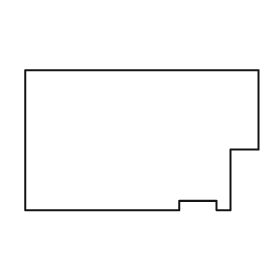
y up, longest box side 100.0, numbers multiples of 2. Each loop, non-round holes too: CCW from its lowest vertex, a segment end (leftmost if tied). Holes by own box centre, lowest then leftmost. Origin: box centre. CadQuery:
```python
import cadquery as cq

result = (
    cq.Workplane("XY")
    .moveTo(-50.0, -30.0)
    .lineTo(16.0, -30.0)
    .lineTo(16.0, -26.0)
    .lineTo(32.0, -26.0)
    .lineTo(32.0, -30.0)
    .lineTo(38.0, -30.0)
    .lineTo(38.0, -4.0)
    .lineTo(50.0, -4.0)
    .lineTo(50.0, 30.0)
    .lineTo(-50.0, 30.0)
    .close()
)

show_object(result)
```